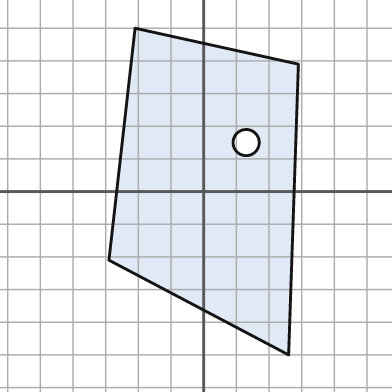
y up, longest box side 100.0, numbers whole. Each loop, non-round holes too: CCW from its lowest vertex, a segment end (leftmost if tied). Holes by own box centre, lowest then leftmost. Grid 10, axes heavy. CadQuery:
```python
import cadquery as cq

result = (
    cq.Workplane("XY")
    .moveTo(26.0, -50.0)
    .lineTo(29.0, 39.0)
    .lineTo(-21.0, 50.0)
    .lineTo(-29.0, -21.0)
    .close()
    .moveTo(13.0, 15.0)
    .circle(4.0)
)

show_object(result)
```